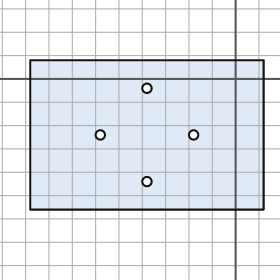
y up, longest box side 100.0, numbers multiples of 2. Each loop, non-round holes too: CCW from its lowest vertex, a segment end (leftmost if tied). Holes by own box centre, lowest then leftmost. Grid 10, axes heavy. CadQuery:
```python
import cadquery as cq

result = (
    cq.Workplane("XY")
    .moveTo(-88.0, -56.0)
    .lineTo(12.0, -56.0)
    .lineTo(12.0, 8.0)
    .lineTo(-88.0, 8.0)
    .close()
    .moveTo(-38.0, -44.0)
    .circle(2.0)
    .moveTo(-58.0, -24.0)
    .circle(2.0)
    .moveTo(-18.0, -24.0)
    .circle(2.0)
    .moveTo(-38.0, -4.0)
    .circle(2.0)
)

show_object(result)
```